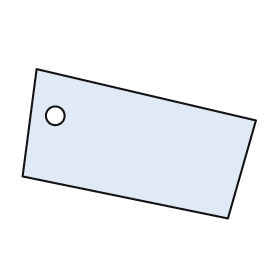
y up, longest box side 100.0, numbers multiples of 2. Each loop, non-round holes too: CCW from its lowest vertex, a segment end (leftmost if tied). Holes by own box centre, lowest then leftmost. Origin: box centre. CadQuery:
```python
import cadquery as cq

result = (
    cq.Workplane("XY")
    .moveTo(38.0, -32.0)
    .lineTo(50.0, 10.0)
    .lineTo(-44.0, 32.0)
    .lineTo(-50.0, -14.0)
    .close()
    .moveTo(-36.0, 12.0)
    .circle(4.0)
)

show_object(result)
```